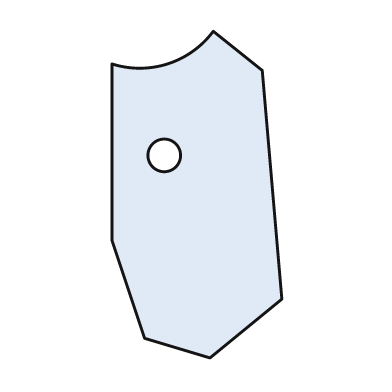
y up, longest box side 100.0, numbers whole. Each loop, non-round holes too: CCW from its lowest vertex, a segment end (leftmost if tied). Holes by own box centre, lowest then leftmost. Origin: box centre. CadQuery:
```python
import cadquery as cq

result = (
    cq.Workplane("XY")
    .moveTo(4.0, -50.0)
    .lineTo(26.0, -32.0)
    .lineTo(20.0, 38.0)
    .lineTo(5.0, 50.0)
    .threePointArc((-9.0, 40.0), (-26.0, 40.0))
    .lineTo(-26.0, -14.0)
    .lineTo(-16.0, -44.0)
    .close()
    .moveTo(-10.0, 12.0)
    .circle(5.0)
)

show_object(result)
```